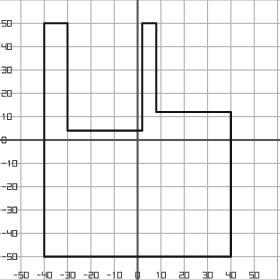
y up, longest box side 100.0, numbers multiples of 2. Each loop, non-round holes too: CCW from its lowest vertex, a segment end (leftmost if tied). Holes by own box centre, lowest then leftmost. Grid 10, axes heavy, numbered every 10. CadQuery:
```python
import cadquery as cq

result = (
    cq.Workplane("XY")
    .moveTo(-40.0, -50.0)
    .lineTo(40.0, -50.0)
    .lineTo(40.0, 12.0)
    .lineTo(8.0, 12.0)
    .lineTo(8.0, 50.0)
    .lineTo(2.0, 50.0)
    .lineTo(2.0, 4.0)
    .lineTo(-30.0, 4.0)
    .lineTo(-30.0, 50.0)
    .lineTo(-40.0, 50.0)
    .close()
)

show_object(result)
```